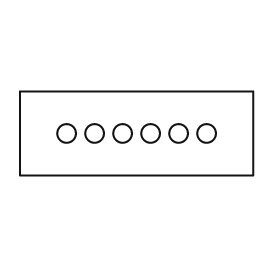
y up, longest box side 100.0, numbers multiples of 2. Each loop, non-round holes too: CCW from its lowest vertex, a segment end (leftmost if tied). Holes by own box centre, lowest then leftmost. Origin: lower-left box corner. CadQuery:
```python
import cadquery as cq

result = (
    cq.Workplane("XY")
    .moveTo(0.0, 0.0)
    .lineTo(100.0, 0.0)
    .lineTo(100.0, 36.0)
    .lineTo(0.0, 36.0)
    .close()
    .moveTo(20.0, 18.0)
    .circle(4.0)
    .moveTo(32.0, 18.0)
    .circle(4.0)
    .moveTo(44.0, 18.0)
    .circle(4.0)
    .moveTo(56.0, 18.0)
    .circle(4.0)
    .moveTo(68.0, 18.0)
    .circle(4.0)
    .moveTo(80.0, 18.0)
    .circle(4.0)
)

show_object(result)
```